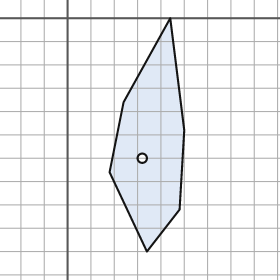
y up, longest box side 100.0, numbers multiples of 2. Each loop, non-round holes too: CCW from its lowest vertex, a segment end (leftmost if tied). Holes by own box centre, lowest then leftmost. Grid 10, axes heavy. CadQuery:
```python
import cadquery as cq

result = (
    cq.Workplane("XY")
    .moveTo(34.0, -100.0)
    .lineTo(48.0, -82.0)
    .lineTo(50.0, -48.0)
    .lineTo(44.0, 0.0)
    .lineTo(24.0, -36.0)
    .lineTo(18.0, -66.0)
    .close()
    .moveTo(32.0, -60.0)
    .circle(2.0)
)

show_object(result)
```